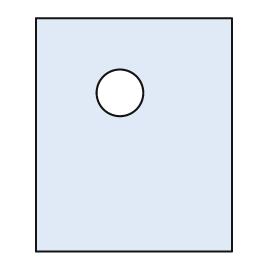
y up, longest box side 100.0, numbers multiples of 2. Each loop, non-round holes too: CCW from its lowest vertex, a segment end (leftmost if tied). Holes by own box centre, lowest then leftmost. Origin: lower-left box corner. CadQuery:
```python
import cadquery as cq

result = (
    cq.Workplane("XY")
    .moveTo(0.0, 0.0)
    .lineTo(84.0, 0.0)
    .lineTo(84.0, 100.0)
    .lineTo(0.0, 100.0)
    .close()
    .moveTo(36.0, 68.0)
    .circle(10.0)
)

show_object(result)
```